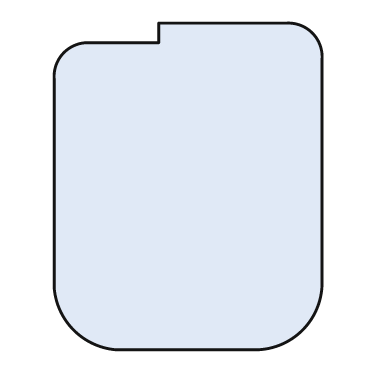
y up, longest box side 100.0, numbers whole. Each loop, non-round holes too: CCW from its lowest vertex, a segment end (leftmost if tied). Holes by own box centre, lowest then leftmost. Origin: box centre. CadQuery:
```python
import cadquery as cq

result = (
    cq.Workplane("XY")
    .moveTo(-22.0, -50.0)
    .lineTo(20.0, -50.0)
    .threePointArc((35.0, -44.0), (41.0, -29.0))
    .lineTo(41.0, 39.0)
    .threePointArc((38.0, 47.0), (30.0, 50.0))
    .lineTo(-9.0, 50.0)
    .lineTo(-9.0, 44.0)
    .lineTo(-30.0, 44.0)
    .threePointArc((-38.0, 41.0), (-41.0, 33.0))
    .lineTo(-41.0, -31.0)
    .threePointArc((-35.0, -44.0), (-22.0, -50.0))
    .close()
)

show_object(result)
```